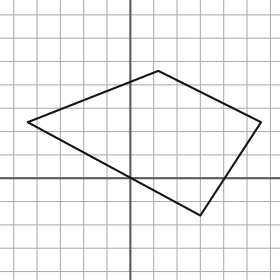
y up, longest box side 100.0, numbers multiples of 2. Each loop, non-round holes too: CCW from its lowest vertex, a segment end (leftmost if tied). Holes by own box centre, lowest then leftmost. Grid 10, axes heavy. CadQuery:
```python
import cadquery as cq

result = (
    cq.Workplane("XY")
    .moveTo(30.0, -16.0)
    .lineTo(56.0, 24.0)
    .lineTo(12.0, 46.0)
    .lineTo(-44.0, 24.0)
    .close()
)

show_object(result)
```